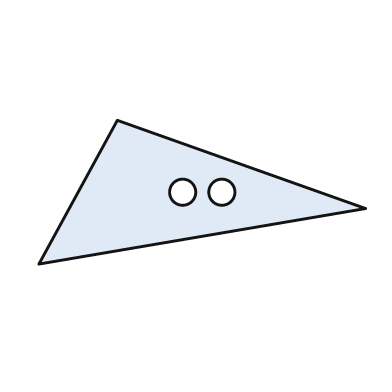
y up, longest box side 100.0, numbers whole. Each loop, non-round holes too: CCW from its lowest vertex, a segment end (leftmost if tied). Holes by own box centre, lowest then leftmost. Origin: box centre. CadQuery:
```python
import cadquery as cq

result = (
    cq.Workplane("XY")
    .moveTo(-50.0, -22.0)
    .lineTo(50.0, -5.0)
    .lineTo(-26.0, 22.0)
    .close()
    .moveTo(-6.0, 0.0)
    .circle(4.0)
    .moveTo(6.0, 0.0)
    .circle(4.0)
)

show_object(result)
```